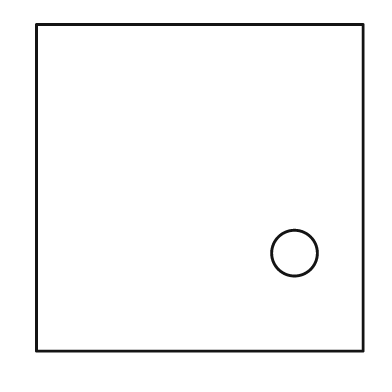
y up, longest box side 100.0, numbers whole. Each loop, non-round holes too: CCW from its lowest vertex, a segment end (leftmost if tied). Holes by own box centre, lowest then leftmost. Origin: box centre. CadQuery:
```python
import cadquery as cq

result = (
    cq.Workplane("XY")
    .moveTo(-50.0, -50.0)
    .lineTo(50.0, -50.0)
    .lineTo(50.0, 50.0)
    .lineTo(-50.0, 50.0)
    .close()
    .moveTo(29.0, -20.0)
    .circle(7.0)
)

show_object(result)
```